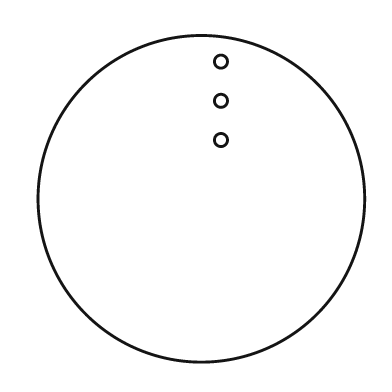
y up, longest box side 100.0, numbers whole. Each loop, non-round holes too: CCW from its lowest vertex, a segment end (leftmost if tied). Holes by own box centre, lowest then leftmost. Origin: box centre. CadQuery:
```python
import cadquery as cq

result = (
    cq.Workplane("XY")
    .moveTo(0.0, 0.0)
    .circle(50.0)
    .moveTo(6.0, 18.0)
    .circle(2.0)
    .moveTo(6.0, 30.0)
    .circle(2.0)
    .moveTo(6.0, 42.0)
    .circle(2.0)
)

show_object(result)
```